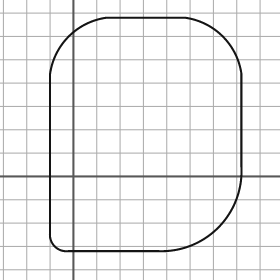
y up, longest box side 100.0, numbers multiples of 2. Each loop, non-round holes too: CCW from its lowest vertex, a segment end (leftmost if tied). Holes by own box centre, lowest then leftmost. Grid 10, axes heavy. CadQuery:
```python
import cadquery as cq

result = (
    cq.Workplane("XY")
    .moveTo(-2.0, -32.0)
    .lineTo(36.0, -32.0)
    .threePointArc((62.0, -22.0), (72.0, 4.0))
    .lineTo(72.0, 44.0)
    .threePointArc((64.0, 60.0), (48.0, 68.0))
    .lineTo(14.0, 68.0)
    .threePointArc((-2.0, 60.0), (-10.0, 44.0))
    .lineTo(-10.0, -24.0)
    .threePointArc((-8.0, -30.0), (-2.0, -32.0))
    .close()
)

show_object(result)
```